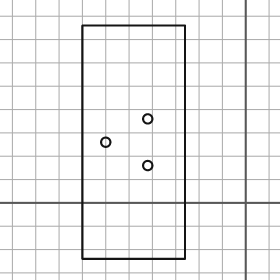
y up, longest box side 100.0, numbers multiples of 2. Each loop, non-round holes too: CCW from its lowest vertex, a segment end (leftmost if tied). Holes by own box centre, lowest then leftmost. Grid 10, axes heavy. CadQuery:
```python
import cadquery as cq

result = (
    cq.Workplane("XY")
    .moveTo(-70.0, -24.0)
    .lineTo(-26.0, -24.0)
    .lineTo(-26.0, 76.0)
    .lineTo(-70.0, 76.0)
    .close()
    .moveTo(-42.0, 16.0)
    .circle(2.0)
    .moveTo(-60.0, 26.0)
    .circle(2.0)
    .moveTo(-42.0, 36.0)
    .circle(2.0)
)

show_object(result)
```